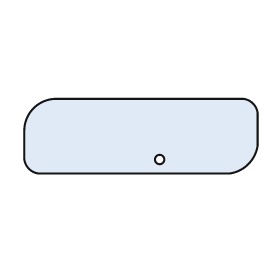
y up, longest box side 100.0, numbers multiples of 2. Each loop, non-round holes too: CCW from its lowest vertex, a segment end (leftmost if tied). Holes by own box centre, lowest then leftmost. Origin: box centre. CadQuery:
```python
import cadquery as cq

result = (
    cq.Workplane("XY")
    .moveTo(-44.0, -16.0)
    .lineTo(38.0, -16.0)
    .threePointArc((46.0, -12.0), (50.0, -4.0))
    .lineTo(50.0, 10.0)
    .threePointArc((48.0, 14.0), (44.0, 16.0))
    .lineTo(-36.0, 16.0)
    .threePointArc((-46.0, 12.0), (-50.0, 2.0))
    .lineTo(-50.0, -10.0)
    .threePointArc((-48.0, -14.0), (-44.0, -16.0))
    .close()
    .moveTo(8.0, -10.0)
    .circle(2.0)
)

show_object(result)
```